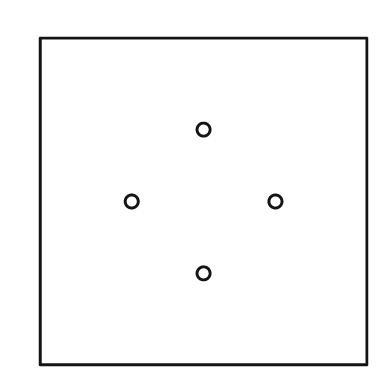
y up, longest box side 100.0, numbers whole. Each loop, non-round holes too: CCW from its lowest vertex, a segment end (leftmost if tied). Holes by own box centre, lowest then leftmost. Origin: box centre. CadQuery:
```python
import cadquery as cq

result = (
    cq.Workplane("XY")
    .moveTo(-50.0, -50.0)
    .lineTo(50.0, -50.0)
    .lineTo(50.0, 50.0)
    .lineTo(-50.0, 50.0)
    .close()
    .moveTo(0.0, -22.0)
    .circle(2.0)
    .moveTo(-22.0, 0.0)
    .circle(2.0)
    .moveTo(22.0, 0.0)
    .circle(2.0)
    .moveTo(0.0, 22.0)
    .circle(2.0)
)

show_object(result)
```